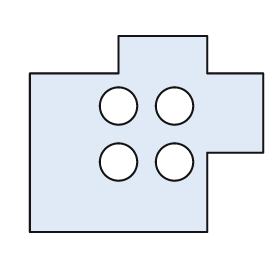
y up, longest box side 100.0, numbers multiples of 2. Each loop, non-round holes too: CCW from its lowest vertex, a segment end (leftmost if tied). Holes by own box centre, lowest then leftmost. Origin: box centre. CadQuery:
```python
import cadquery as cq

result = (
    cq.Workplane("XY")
    .moveTo(-50.0, -42.0)
    .lineTo(26.0, -42.0)
    .lineTo(26.0, -8.0)
    .lineTo(50.0, -8.0)
    .lineTo(50.0, 26.0)
    .lineTo(26.0, 26.0)
    .lineTo(26.0, 42.0)
    .lineTo(-12.0, 42.0)
    .lineTo(-12.0, 26.0)
    .lineTo(-50.0, 26.0)
    .close()
    .moveTo(-12.0, -12.0)
    .circle(8.0)
    .moveTo(12.0, -12.0)
    .circle(8.0)
    .moveTo(-12.0, 12.0)
    .circle(8.0)
    .moveTo(12.0, 12.0)
    .circle(8.0)
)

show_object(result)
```